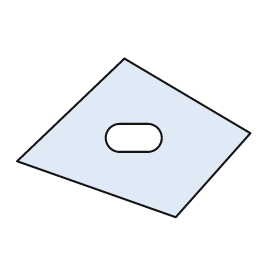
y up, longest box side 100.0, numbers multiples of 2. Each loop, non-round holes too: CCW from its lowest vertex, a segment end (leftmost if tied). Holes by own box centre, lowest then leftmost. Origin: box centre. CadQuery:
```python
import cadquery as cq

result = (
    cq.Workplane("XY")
    .moveTo(18.0, -34.0)
    .lineTo(50.0, 2.0)
    .lineTo(-4.0, 34.0)
    .lineTo(-50.0, -10.0)
    .close()
    .moveTo(-6.0, -6.0)
    .lineTo(6.0, -6.0)
    .threePointArc((12.0, 0.0), (6.0, 6.0))
    .lineTo(-6.0, 6.0)
    .threePointArc((-12.0, 0.0), (-6.0, -6.0))
    .close()
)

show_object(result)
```